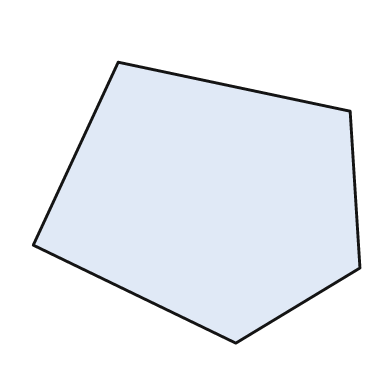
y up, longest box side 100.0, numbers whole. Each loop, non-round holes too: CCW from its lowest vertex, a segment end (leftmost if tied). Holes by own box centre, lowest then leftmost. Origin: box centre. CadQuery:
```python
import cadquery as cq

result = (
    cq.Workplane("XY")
    .moveTo(12.0, -43.0)
    .lineTo(50.0, -20.0)
    .lineTo(47.0, 28.0)
    .lineTo(-24.0, 43.0)
    .lineTo(-50.0, -13.0)
    .close()
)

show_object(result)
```